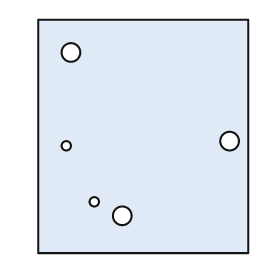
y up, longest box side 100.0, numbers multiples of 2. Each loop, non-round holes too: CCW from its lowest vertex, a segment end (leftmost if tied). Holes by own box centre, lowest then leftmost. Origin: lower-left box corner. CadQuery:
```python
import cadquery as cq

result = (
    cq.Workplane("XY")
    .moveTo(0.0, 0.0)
    .lineTo(90.0, 0.0)
    .lineTo(90.0, 100.0)
    .lineTo(0.0, 100.0)
    .close()
    .moveTo(36.0, 16.0)
    .circle(4.0)
    .moveTo(24.0, 22.0)
    .circle(2.0)
    .moveTo(12.0, 46.0)
    .circle(2.0)
    .moveTo(82.0, 48.0)
    .circle(4.0)
    .moveTo(14.0, 86.0)
    .circle(4.0)
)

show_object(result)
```